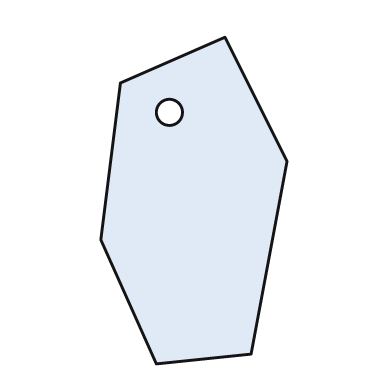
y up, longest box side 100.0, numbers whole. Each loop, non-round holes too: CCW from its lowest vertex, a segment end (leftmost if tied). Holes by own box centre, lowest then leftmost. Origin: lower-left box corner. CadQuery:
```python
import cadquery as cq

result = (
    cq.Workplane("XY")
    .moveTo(17.0, 0.0)
    .lineTo(46.0, 3.0)
    .lineTo(57.0, 62.0)
    .lineTo(38.0, 100.0)
    .lineTo(6.0, 86.0)
    .lineTo(0.0, 38.0)
    .close()
    .moveTo(21.0, 77.0)
    .circle(4.0)
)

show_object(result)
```